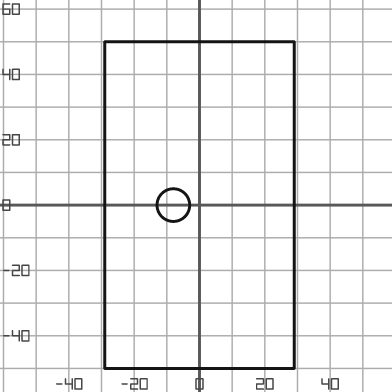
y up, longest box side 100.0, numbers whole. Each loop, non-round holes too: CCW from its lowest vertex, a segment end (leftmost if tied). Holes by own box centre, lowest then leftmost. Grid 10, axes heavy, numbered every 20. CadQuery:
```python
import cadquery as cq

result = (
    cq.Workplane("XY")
    .moveTo(-29.0, -50.0)
    .lineTo(29.0, -50.0)
    .lineTo(29.0, 50.0)
    .lineTo(-29.0, 50.0)
    .close()
    .moveTo(-8.0, 0.0)
    .circle(5.0)
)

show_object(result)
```